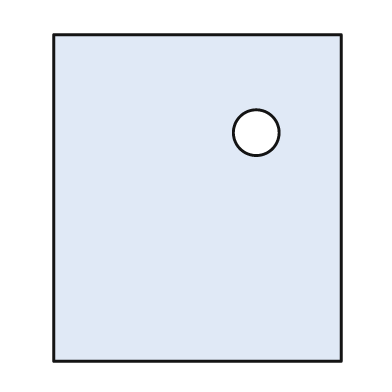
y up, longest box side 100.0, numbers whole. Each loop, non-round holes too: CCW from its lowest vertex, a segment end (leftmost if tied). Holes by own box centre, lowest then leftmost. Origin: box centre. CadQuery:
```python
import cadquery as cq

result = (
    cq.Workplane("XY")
    .moveTo(-44.0, -50.0)
    .lineTo(44.0, -50.0)
    .lineTo(44.0, 50.0)
    .lineTo(-44.0, 50.0)
    .close()
    .moveTo(18.0, 20.0)
    .circle(7.0)
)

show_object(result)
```